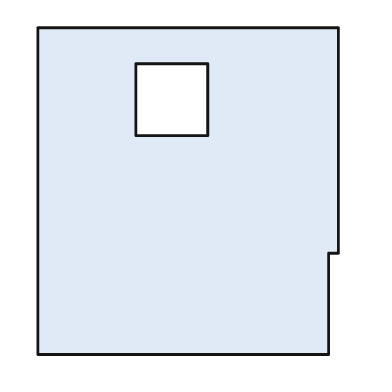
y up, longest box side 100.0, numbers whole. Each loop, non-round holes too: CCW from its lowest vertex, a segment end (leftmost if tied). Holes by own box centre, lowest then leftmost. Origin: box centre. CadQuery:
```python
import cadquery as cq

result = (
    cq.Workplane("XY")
    .moveTo(-46.0, -50.0)
    .lineTo(43.0, -50.0)
    .lineTo(43.0, -19.0)
    .lineTo(46.0, -19.0)
    .lineTo(46.0, 50.0)
    .lineTo(-46.0, 50.0)
    .close()
    .moveTo(-16.0, 17.0)
    .lineTo(6.0, 17.0)
    .lineTo(6.0, 39.0)
    .lineTo(-16.0, 39.0)
    .close()
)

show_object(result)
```